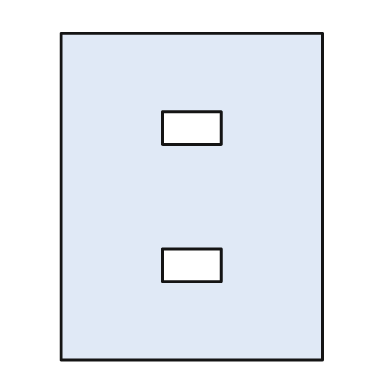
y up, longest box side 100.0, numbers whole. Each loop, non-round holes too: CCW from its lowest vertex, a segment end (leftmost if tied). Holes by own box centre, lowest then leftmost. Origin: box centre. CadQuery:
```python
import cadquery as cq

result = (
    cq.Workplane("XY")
    .moveTo(-40.0, -50.0)
    .lineTo(40.0, -50.0)
    .lineTo(40.0, 50.0)
    .lineTo(-40.0, 50.0)
    .close()
    .moveTo(-9.0, -26.0)
    .lineTo(9.0, -26.0)
    .lineTo(9.0, -16.0)
    .lineTo(-9.0, -16.0)
    .close()
    .moveTo(-9.0, 16.0)
    .lineTo(9.0, 16.0)
    .lineTo(9.0, 26.0)
    .lineTo(-9.0, 26.0)
    .close()
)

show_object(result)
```